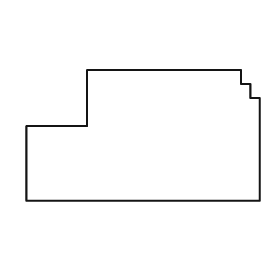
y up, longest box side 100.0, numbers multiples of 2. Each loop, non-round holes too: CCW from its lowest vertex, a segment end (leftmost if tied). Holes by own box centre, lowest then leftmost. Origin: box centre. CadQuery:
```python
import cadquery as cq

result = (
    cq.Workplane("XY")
    .moveTo(-50.0, -28.0)
    .lineTo(50.0, -28.0)
    .lineTo(50.0, 16.0)
    .lineTo(46.0, 16.0)
    .lineTo(46.0, 22.0)
    .lineTo(42.0, 22.0)
    .lineTo(42.0, 28.0)
    .lineTo(-24.0, 28.0)
    .lineTo(-24.0, 4.0)
    .lineTo(-50.0, 4.0)
    .close()
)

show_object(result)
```